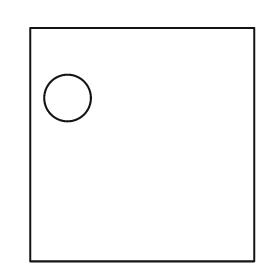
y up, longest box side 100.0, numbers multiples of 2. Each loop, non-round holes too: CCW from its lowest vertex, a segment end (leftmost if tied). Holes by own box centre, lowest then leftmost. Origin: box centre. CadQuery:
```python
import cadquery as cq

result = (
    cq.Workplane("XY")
    .moveTo(-48.0, -50.0)
    .lineTo(48.0, -50.0)
    .lineTo(48.0, 50.0)
    .lineTo(-48.0, 50.0)
    .close()
    .moveTo(-32.0, 20.0)
    .circle(10.0)
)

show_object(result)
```